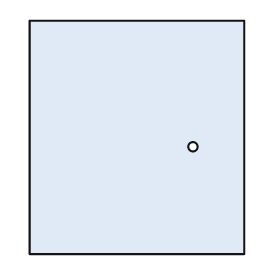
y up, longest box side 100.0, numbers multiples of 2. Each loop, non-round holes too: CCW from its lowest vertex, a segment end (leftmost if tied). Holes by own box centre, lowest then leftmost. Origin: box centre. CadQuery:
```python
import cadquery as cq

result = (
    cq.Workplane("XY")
    .moveTo(-46.0, -50.0)
    .lineTo(46.0, -50.0)
    .lineTo(46.0, 50.0)
    .lineTo(-46.0, 50.0)
    .close()
    .moveTo(24.0, -4.0)
    .circle(2.0)
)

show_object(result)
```